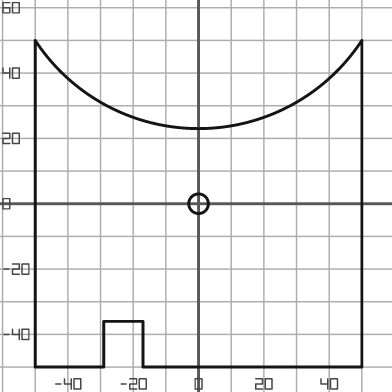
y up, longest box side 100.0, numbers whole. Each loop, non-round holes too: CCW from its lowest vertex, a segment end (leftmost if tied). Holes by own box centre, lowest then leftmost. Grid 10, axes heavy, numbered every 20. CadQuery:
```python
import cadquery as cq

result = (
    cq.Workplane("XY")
    .moveTo(-50.0, -50.0)
    .lineTo(-29.0, -50.0)
    .lineTo(-29.0, -36.0)
    .lineTo(-17.0, -36.0)
    .lineTo(-17.0, -50.0)
    .lineTo(50.0, -50.0)
    .lineTo(50.0, 50.0)
    .threePointArc((0.0, 23.0), (-50.0, 50.0))
    .close()
    .moveTo(0.0, 0.0)
    .circle(3.0)
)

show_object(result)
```